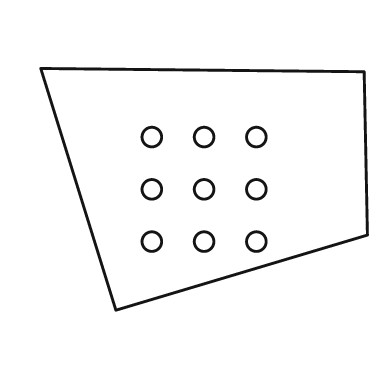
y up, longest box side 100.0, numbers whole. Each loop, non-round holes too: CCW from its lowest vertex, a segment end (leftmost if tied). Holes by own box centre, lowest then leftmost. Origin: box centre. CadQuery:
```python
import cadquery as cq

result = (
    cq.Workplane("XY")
    .moveTo(-27.0, -37.0)
    .lineTo(50.0, -14.0)
    .lineTo(49.0, 36.0)
    .lineTo(-50.0, 37.0)
    .close()
    .moveTo(-16.0, -16.0)
    .circle(3.0)
    .moveTo(0.0, -16.0)
    .circle(3.0)
    .moveTo(16.0, -16.0)
    .circle(3.0)
    .moveTo(-16.0, 0.0)
    .circle(3.0)
    .moveTo(0.0, 0.0)
    .circle(3.0)
    .moveTo(16.0, 0.0)
    .circle(3.0)
    .moveTo(-16.0, 16.0)
    .circle(3.0)
    .moveTo(0.0, 16.0)
    .circle(3.0)
    .moveTo(16.0, 16.0)
    .circle(3.0)
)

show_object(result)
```